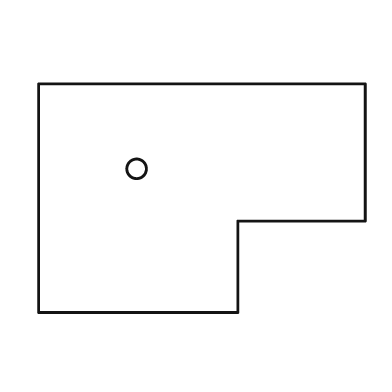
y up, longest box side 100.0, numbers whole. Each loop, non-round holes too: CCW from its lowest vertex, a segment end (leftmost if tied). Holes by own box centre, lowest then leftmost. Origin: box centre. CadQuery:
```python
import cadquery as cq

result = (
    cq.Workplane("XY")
    .moveTo(-50.0, -35.0)
    .lineTo(11.0, -35.0)
    .lineTo(11.0, -7.0)
    .lineTo(50.0, -7.0)
    .lineTo(50.0, 35.0)
    .lineTo(-50.0, 35.0)
    .close()
    .moveTo(-20.0, 9.0)
    .circle(3.0)
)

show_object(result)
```